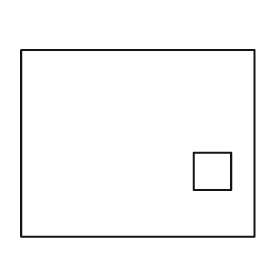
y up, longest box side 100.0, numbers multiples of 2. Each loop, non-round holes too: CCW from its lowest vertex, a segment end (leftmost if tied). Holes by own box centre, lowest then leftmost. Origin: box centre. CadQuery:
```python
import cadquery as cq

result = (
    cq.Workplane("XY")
    .moveTo(-50.0, -40.0)
    .lineTo(50.0, -40.0)
    .lineTo(50.0, 40.0)
    .lineTo(-50.0, 40.0)
    .close()
    .moveTo(24.0, -20.0)
    .lineTo(40.0, -20.0)
    .lineTo(40.0, -4.0)
    .lineTo(24.0, -4.0)
    .close()
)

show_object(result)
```